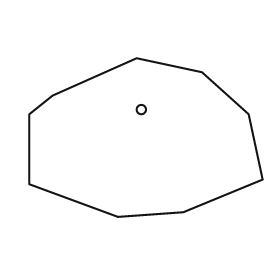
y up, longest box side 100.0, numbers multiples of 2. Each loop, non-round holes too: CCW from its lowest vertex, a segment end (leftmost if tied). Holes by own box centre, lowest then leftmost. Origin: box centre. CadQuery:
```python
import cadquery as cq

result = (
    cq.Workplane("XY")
    .moveTo(-12.0, -34.0)
    .lineTo(16.0, -32.0)
    .lineTo(50.0, -18.0)
    .lineTo(44.0, 10.0)
    .lineTo(24.0, 28.0)
    .lineTo(-4.0, 34.0)
    .lineTo(-40.0, 18.0)
    .lineTo(-50.0, 10.0)
    .lineTo(-50.0, -20.0)
    .close()
    .moveTo(-2.0, 12.0)
    .circle(2.0)
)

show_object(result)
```